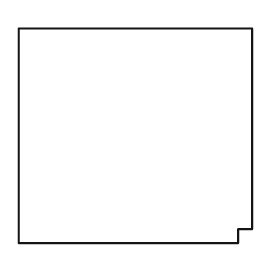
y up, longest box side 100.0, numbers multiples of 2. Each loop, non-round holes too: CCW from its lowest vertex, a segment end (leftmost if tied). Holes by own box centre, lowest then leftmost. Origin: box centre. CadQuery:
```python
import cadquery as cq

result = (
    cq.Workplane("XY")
    .moveTo(-50.0, -46.0)
    .lineTo(44.0, -46.0)
    .lineTo(44.0, -40.0)
    .lineTo(50.0, -40.0)
    .lineTo(50.0, 46.0)
    .lineTo(-50.0, 46.0)
    .close()
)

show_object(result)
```